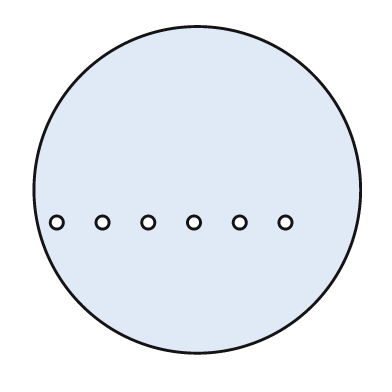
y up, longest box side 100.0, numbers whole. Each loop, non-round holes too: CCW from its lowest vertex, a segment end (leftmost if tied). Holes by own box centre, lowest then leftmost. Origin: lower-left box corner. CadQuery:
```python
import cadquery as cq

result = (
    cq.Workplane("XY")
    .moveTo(50.0, 50.0)
    .circle(50.0)
    .moveTo(7.0, 40.0)
    .circle(2.0)
    .moveTo(21.0, 40.0)
    .circle(2.0)
    .moveTo(35.0, 40.0)
    .circle(2.0)
    .moveTo(49.0, 40.0)
    .circle(2.0)
    .moveTo(63.0, 40.0)
    .circle(2.0)
    .moveTo(77.0, 40.0)
    .circle(2.0)
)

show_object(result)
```